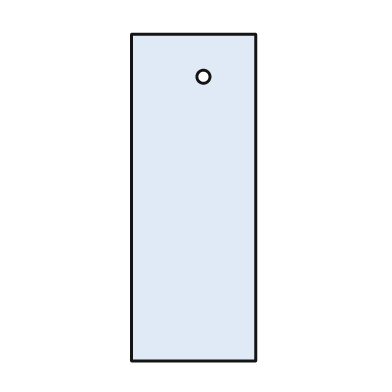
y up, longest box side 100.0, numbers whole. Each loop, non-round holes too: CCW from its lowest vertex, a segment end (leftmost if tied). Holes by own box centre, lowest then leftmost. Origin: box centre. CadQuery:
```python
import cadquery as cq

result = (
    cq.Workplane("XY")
    .moveTo(-19.0, -50.0)
    .lineTo(19.0, -50.0)
    .lineTo(19.0, 50.0)
    .lineTo(-19.0, 50.0)
    .close()
    .moveTo(3.0, 37.0)
    .circle(2.0)
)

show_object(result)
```